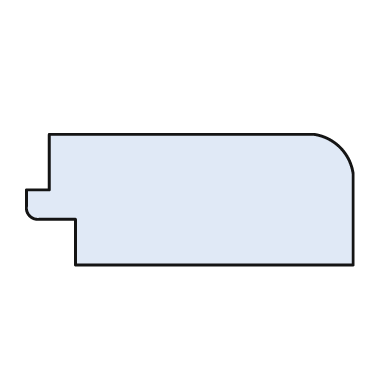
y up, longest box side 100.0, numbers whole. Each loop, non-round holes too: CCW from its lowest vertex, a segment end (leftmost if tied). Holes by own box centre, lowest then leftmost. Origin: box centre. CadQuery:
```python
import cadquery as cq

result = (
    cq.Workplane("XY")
    .moveTo(-35.0, -20.0)
    .lineTo(50.0, -20.0)
    .lineTo(50.0, 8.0)
    .threePointArc((46.0, 16.0), (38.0, 20.0))
    .lineTo(-43.0, 20.0)
    .lineTo(-43.0, 3.0)
    .lineTo(-50.0, 3.0)
    .lineTo(-50.0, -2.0)
    .threePointArc((-49.0, -5.0), (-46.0, -6.0))
    .lineTo(-35.0, -6.0)
    .close()
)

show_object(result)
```